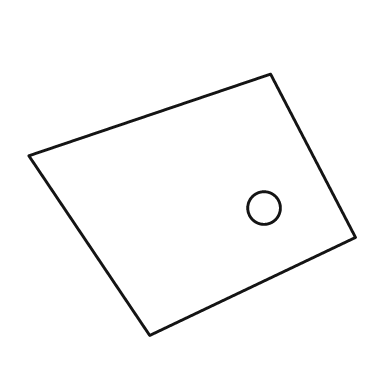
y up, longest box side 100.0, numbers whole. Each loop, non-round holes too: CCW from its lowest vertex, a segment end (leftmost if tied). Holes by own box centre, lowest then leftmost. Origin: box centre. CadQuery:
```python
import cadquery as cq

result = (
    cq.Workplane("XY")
    .moveTo(-13.0, -40.0)
    .lineTo(50.0, -10.0)
    .lineTo(24.0, 40.0)
    .lineTo(-50.0, 15.0)
    .close()
    .moveTo(22.0, -1.0)
    .circle(5.0)
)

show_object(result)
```